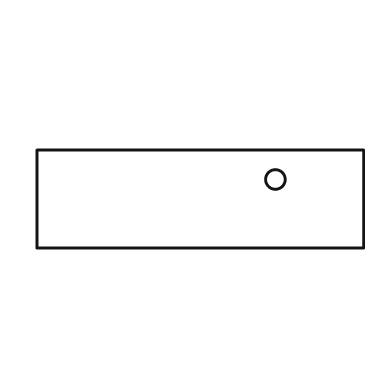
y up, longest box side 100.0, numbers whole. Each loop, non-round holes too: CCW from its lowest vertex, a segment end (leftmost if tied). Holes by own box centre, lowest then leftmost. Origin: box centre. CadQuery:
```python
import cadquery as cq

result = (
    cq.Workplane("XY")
    .moveTo(-50.0, -15.0)
    .lineTo(50.0, -15.0)
    .lineTo(50.0, 15.0)
    .lineTo(-50.0, 15.0)
    .close()
    .moveTo(23.0, 6.0)
    .circle(3.0)
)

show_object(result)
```